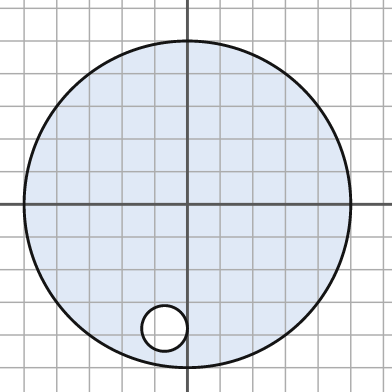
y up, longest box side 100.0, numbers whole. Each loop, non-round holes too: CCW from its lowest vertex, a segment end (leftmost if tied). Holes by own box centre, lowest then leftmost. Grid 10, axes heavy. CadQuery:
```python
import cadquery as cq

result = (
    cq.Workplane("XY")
    .moveTo(0.0, 0.0)
    .circle(50.0)
    .moveTo(-7.0, -38.0)
    .circle(7.0)
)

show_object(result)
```